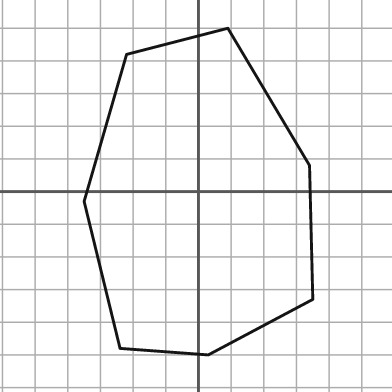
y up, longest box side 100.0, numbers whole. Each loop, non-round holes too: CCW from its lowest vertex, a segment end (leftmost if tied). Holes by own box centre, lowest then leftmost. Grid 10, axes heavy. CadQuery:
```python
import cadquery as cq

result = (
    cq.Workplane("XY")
    .moveTo(3.0, -50.0)
    .lineTo(35.0, -33.0)
    .lineTo(34.0, 8.0)
    .lineTo(9.0, 50.0)
    .lineTo(-22.0, 42.0)
    .lineTo(-35.0, -3.0)
    .lineTo(-24.0, -48.0)
    .close()
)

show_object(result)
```